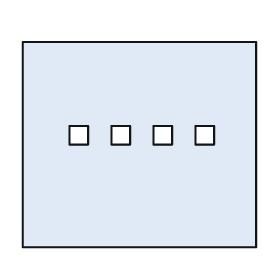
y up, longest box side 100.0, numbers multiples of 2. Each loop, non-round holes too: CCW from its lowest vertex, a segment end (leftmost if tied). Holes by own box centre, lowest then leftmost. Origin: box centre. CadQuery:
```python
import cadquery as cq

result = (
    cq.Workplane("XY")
    .moveTo(-50.0, -44.0)
    .lineTo(50.0, -44.0)
    .lineTo(50.0, 44.0)
    .lineTo(-50.0, 44.0)
    .close()
    .moveTo(-30.0, 0.0)
    .lineTo(-22.0, 0.0)
    .lineTo(-22.0, 8.0)
    .lineTo(-30.0, 8.0)
    .close()
    .moveTo(-12.0, 0.0)
    .lineTo(-4.0, 0.0)
    .lineTo(-4.0, 8.0)
    .lineTo(-12.0, 8.0)
    .close()
    .moveTo(6.0, 0.0)
    .lineTo(14.0, 0.0)
    .lineTo(14.0, 8.0)
    .lineTo(6.0, 8.0)
    .close()
    .moveTo(24.0, 0.0)
    .lineTo(32.0, 0.0)
    .lineTo(32.0, 8.0)
    .lineTo(24.0, 8.0)
    .close()
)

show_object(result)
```